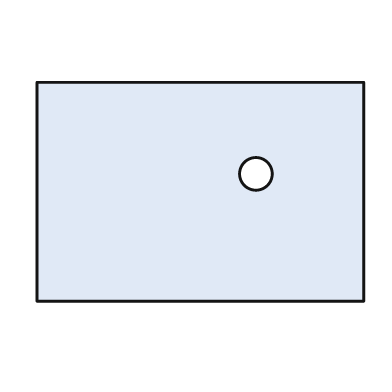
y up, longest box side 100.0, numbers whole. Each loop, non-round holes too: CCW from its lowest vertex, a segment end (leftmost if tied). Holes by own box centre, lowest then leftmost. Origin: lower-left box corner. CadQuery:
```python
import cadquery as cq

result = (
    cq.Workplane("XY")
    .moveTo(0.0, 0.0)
    .lineTo(100.0, 0.0)
    .lineTo(100.0, 67.0)
    .lineTo(0.0, 67.0)
    .close()
    .moveTo(67.0, 39.0)
    .circle(5.0)
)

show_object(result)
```